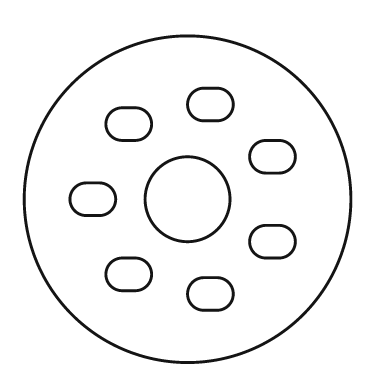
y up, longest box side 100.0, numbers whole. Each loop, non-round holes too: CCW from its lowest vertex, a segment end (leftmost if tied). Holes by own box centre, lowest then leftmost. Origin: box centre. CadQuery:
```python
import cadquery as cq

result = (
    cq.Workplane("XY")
    .moveTo(0.0, 0.0)
    .circle(50.0)
    .moveTo(5.0, -34.0)
    .lineTo(9.0, -34.0)
    .threePointArc((14.0, -29.0), (9.0, -24.0))
    .lineTo(5.0, -24.0)
    .threePointArc((0.0, -29.0), (5.0, -34.0))
    .close()
    .moveTo(-20.0, -28.0)
    .lineTo(-16.0, -28.0)
    .threePointArc((-11.0, -23.0), (-16.0, -18.0))
    .lineTo(-20.0, -18.0)
    .threePointArc((-25.0, -23.0), (-20.0, -28.0))
    .close()
    .moveTo(24.0, -18.0)
    .lineTo(28.0, -18.0)
    .threePointArc((33.0, -13.0), (28.0, -8.0))
    .lineTo(24.0, -8.0)
    .threePointArc((19.0, -13.0), (24.0, -18.0))
    .close()
    .moveTo(-31.0, -5.0)
    .lineTo(-27.0, -5.0)
    .threePointArc((-22.0, 0.0), (-27.0, 5.0))
    .lineTo(-31.0, 5.0)
    .threePointArc((-36.0, 0.0), (-31.0, -5.0))
    .close()
    .moveTo(0.0, 0.0)
    .circle(13.0)
    .moveTo(24.0, 8.0)
    .lineTo(28.0, 8.0)
    .threePointArc((33.0, 13.0), (28.0, 18.0))
    .lineTo(24.0, 18.0)
    .threePointArc((19.0, 13.0), (24.0, 8.0))
    .close()
    .moveTo(-20.0, 18.0)
    .lineTo(-16.0, 18.0)
    .threePointArc((-11.0, 23.0), (-16.0, 28.0))
    .lineTo(-20.0, 28.0)
    .threePointArc((-25.0, 23.0), (-20.0, 18.0))
    .close()
    .moveTo(5.0, 24.0)
    .lineTo(9.0, 24.0)
    .threePointArc((14.0, 29.0), (9.0, 34.0))
    .lineTo(5.0, 34.0)
    .threePointArc((0.0, 29.0), (5.0, 24.0))
    .close()
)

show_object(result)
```